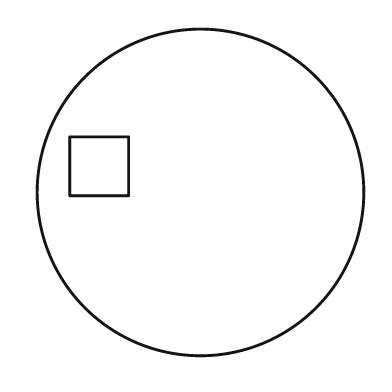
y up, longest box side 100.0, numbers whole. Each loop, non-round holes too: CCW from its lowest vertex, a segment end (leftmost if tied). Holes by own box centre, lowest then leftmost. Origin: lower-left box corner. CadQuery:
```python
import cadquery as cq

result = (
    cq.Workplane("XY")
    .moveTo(50.0, 50.0)
    .circle(50.0)
    .moveTo(10.0, 49.0)
    .lineTo(28.0, 49.0)
    .lineTo(28.0, 67.0)
    .lineTo(10.0, 67.0)
    .close()
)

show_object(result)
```